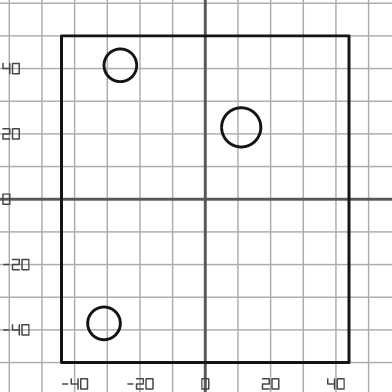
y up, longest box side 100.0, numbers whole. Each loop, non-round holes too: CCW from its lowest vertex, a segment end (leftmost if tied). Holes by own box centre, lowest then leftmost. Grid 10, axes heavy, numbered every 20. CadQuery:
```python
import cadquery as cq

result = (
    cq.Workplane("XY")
    .moveTo(-44.0, -50.0)
    .lineTo(44.0, -50.0)
    .lineTo(44.0, 50.0)
    .lineTo(-44.0, 50.0)
    .close()
    .moveTo(-31.0, -38.0)
    .circle(5.0)
    .moveTo(11.0, 22.0)
    .circle(6.0)
    .moveTo(-26.0, 41.0)
    .circle(5.0)
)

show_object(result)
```